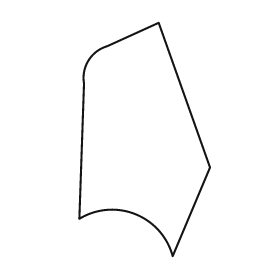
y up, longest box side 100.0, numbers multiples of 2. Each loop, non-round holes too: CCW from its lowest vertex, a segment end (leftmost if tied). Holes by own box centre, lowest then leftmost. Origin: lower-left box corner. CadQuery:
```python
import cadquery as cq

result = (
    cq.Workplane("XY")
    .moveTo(40.0, 0.0)
    .lineTo(56.0, 38.0)
    .lineTo(34.0, 100.0)
    .lineTo(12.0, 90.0)
    .threePointArc((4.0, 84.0), (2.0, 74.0))
    .lineTo(0.0, 16.0)
    .threePointArc((24.0, 18.0), (40.0, 0.0))
    .close()
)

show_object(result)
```